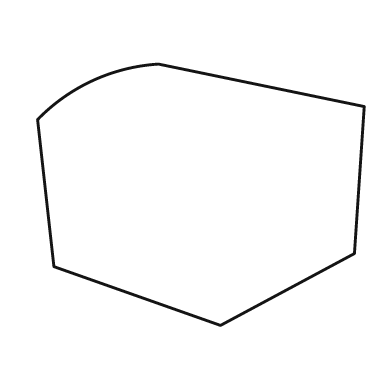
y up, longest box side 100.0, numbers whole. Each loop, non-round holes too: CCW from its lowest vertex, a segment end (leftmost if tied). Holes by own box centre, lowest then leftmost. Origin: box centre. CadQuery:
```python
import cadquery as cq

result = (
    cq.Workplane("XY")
    .moveTo(6.0, -40.0)
    .lineTo(47.0, -18.0)
    .lineTo(50.0, 27.0)
    .lineTo(-13.0, 40.0)
    .threePointArc((-33.0, 35.0), (-50.0, 23.0))
    .lineTo(-45.0, -22.0)
    .close()
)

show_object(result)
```